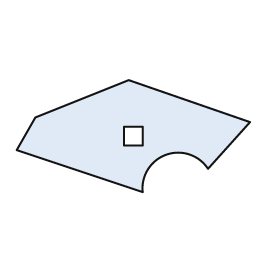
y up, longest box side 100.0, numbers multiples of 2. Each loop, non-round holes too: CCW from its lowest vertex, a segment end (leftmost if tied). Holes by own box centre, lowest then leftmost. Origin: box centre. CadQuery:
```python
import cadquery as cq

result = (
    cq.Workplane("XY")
    .moveTo(4.0, -24.0)
    .threePointArc((14.0, -8.0), (32.0, -14.0))
    .lineTo(50.0, 6.0)
    .lineTo(-2.0, 24.0)
    .lineTo(-42.0, 8.0)
    .lineTo(-50.0, -6.0)
    .close()
    .moveTo(-4.0, -4.0)
    .lineTo(4.0, -4.0)
    .lineTo(4.0, 4.0)
    .lineTo(-4.0, 4.0)
    .close()
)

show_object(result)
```